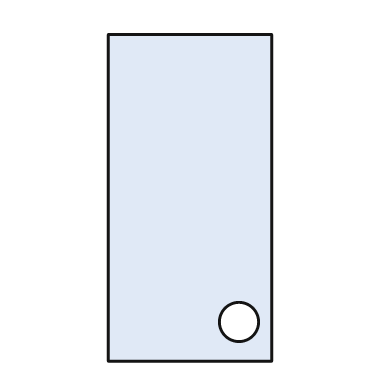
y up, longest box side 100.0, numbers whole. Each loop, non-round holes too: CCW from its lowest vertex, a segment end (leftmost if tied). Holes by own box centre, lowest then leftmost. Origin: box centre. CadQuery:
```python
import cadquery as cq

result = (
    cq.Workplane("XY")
    .moveTo(-25.0, -50.0)
    .lineTo(25.0, -50.0)
    .lineTo(25.0, 50.0)
    .lineTo(-25.0, 50.0)
    .close()
    .moveTo(15.0, -38.0)
    .circle(6.0)
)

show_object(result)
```